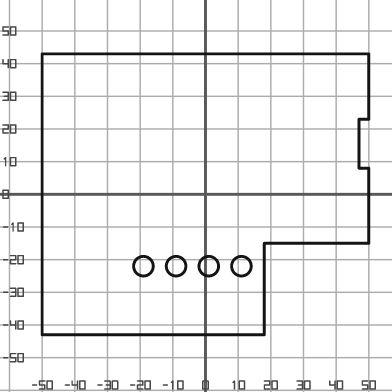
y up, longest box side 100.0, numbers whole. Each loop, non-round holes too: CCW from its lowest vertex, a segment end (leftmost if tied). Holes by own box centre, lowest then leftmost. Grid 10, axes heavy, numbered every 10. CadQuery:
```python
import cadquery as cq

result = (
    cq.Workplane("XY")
    .moveTo(-50.0, -43.0)
    .lineTo(18.0, -43.0)
    .lineTo(18.0, -15.0)
    .lineTo(50.0, -15.0)
    .lineTo(50.0, 8.0)
    .lineTo(47.0, 8.0)
    .lineTo(47.0, 23.0)
    .lineTo(50.0, 23.0)
    .lineTo(50.0, 43.0)
    .lineTo(-50.0, 43.0)
    .close()
    .moveTo(-19.0, -22.0)
    .circle(3.0)
    .moveTo(-9.0, -22.0)
    .circle(3.0)
    .moveTo(1.0, -22.0)
    .circle(3.0)
    .moveTo(11.0, -22.0)
    .circle(3.0)
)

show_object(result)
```